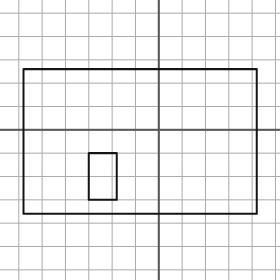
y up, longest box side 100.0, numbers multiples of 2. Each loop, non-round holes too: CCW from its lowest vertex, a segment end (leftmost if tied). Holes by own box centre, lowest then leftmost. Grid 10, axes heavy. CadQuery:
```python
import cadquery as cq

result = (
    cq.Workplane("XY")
    .moveTo(-58.0, -36.0)
    .lineTo(42.0, -36.0)
    .lineTo(42.0, 26.0)
    .lineTo(-58.0, 26.0)
    .close()
    .moveTo(-30.0, -30.0)
    .lineTo(-18.0, -30.0)
    .lineTo(-18.0, -10.0)
    .lineTo(-30.0, -10.0)
    .close()
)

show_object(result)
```